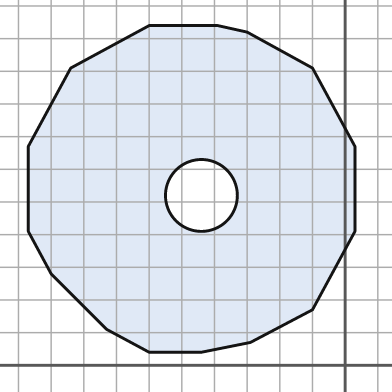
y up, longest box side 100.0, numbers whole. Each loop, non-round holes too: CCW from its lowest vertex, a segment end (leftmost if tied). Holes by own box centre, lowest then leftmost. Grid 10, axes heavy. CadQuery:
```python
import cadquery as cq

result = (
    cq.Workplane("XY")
    .moveTo(-60.0, 4.0)
    .lineTo(-44.0, 4.0)
    .lineTo(-29.0, 7.0)
    .lineTo(-10.0, 17.0)
    .lineTo(3.0, 41.0)
    .lineTo(3.0, 67.0)
    .lineTo(-10.0, 91.0)
    .lineTo(-30.0, 102.0)
    .lineTo(-39.0, 104.0)
    .lineTo(-60.0, 104.0)
    .lineTo(-84.0, 91.0)
    .lineTo(-97.0, 67.0)
    .lineTo(-97.0, 41.0)
    .lineTo(-90.0, 28.0)
    .lineTo(-73.0, 11.0)
    .close()
    .moveTo(-44.0, 52.0)
    .circle(11.0)
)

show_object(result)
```